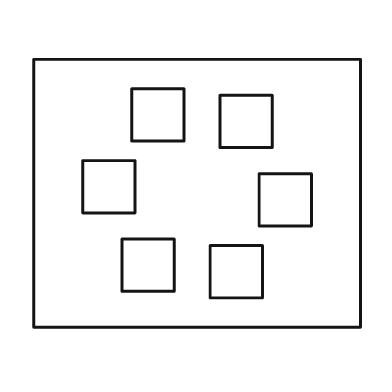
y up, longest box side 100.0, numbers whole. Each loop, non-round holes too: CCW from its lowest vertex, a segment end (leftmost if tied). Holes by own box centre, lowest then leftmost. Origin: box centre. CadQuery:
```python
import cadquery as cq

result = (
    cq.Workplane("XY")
    .moveTo(-50.0, -41.0)
    .lineTo(50.0, -41.0)
    .lineTo(50.0, 41.0)
    .lineTo(-50.0, 41.0)
    .close()
    .moveTo(4.0, -32.0)
    .lineTo(20.0, -32.0)
    .lineTo(20.0, -16.0)
    .lineTo(4.0, -16.0)
    .close()
    .moveTo(-23.0, -30.0)
    .lineTo(-7.0, -30.0)
    .lineTo(-7.0, -14.0)
    .lineTo(-23.0, -14.0)
    .close()
    .moveTo(19.0, -10.0)
    .lineTo(35.0, -10.0)
    .lineTo(35.0, 6.0)
    .lineTo(19.0, 6.0)
    .close()
    .moveTo(-35.0, -6.0)
    .lineTo(-19.0, -6.0)
    .lineTo(-19.0, 10.0)
    .lineTo(-35.0, 10.0)
    .close()
    .moveTo(7.0, 14.0)
    .lineTo(23.0, 14.0)
    .lineTo(23.0, 30.0)
    .lineTo(7.0, 30.0)
    .close()
    .moveTo(-20.0, 16.0)
    .lineTo(-4.0, 16.0)
    .lineTo(-4.0, 32.0)
    .lineTo(-20.0, 32.0)
    .close()
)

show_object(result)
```